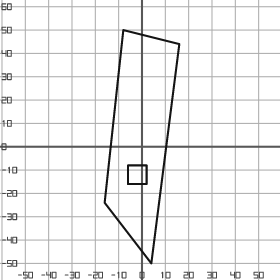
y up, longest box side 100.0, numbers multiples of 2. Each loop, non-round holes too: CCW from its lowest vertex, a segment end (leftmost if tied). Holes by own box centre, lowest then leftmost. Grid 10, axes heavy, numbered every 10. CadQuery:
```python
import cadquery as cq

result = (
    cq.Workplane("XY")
    .moveTo(4.0, -50.0)
    .lineTo(16.0, 44.0)
    .lineTo(-8.0, 50.0)
    .lineTo(-16.0, -24.0)
    .close()
    .moveTo(-6.0, -16.0)
    .lineTo(2.0, -16.0)
    .lineTo(2.0, -8.0)
    .lineTo(-6.0, -8.0)
    .close()
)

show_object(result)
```